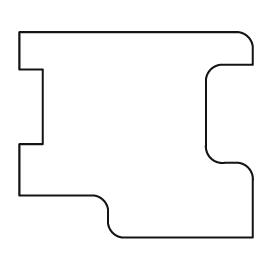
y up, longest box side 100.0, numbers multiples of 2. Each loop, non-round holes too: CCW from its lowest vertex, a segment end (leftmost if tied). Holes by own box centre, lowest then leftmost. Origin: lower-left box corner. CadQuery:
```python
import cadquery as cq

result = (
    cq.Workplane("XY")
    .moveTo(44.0, 0.0)
    .lineTo(100.0, 0.0)
    .lineTo(100.0, 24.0)
    .threePointArc((98.0, 30.0), (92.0, 32.0))
    .lineTo(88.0, 32.0)
    .threePointArc((82.0, 34.0), (80.0, 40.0))
    .lineTo(80.0, 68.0)
    .threePointArc((82.0, 72.0), (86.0, 74.0))
    .lineTo(100.0, 74.0)
    .lineTo(100.0, 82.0)
    .threePointArc((98.0, 86.0), (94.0, 88.0))
    .lineTo(0.0, 88.0)
    .lineTo(0.0, 72.0)
    .lineTo(10.0, 72.0)
    .lineTo(10.0, 40.0)
    .lineTo(0.0, 40.0)
    .lineTo(0.0, 18.0)
    .lineTo(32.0, 18.0)
    .threePointArc((36.0, 16.0), (38.0, 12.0))
    .lineTo(38.0, 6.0)
    .threePointArc((40.0, 2.0), (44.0, 0.0))
    .close()
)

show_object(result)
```